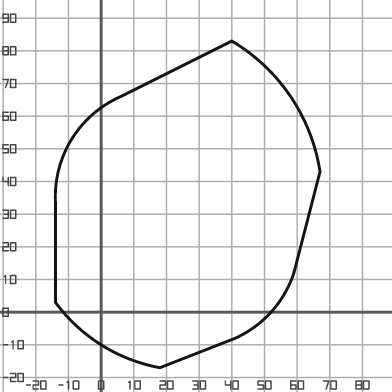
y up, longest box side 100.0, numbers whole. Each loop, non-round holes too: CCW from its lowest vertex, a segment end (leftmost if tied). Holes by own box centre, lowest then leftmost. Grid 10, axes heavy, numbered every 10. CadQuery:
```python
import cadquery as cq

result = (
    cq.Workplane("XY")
    .moveTo(18.0, -17.0)
    .lineTo(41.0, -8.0)
    .threePointArc((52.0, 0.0), (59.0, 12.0))
    .lineTo(67.0, 43.0)
    .threePointArc((58.0, 66.0), (40.0, 83.0))
    .lineTo(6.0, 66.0)
    .threePointArc((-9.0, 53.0), (-14.0, 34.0))
    .lineTo(-14.0, 3.0)
    .threePointArc((0.0, -10.0), (18.0, -17.0))
    .close()
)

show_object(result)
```